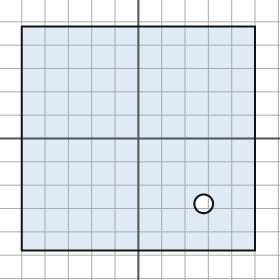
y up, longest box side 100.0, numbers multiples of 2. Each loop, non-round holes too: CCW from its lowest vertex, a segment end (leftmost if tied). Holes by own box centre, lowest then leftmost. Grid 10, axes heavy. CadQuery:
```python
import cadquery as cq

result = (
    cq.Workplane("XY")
    .moveTo(-50.0, -48.0)
    .lineTo(50.0, -48.0)
    .lineTo(50.0, 48.0)
    .lineTo(-50.0, 48.0)
    .close()
    .moveTo(28.0, -28.0)
    .circle(4.0)
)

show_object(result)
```